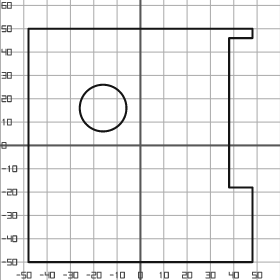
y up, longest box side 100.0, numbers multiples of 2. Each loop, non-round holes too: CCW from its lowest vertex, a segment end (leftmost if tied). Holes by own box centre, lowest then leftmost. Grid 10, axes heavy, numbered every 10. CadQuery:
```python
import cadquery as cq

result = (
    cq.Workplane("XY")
    .moveTo(-48.0, -50.0)
    .lineTo(48.0, -50.0)
    .lineTo(48.0, -18.0)
    .lineTo(38.0, -18.0)
    .lineTo(38.0, 46.0)
    .lineTo(48.0, 46.0)
    .lineTo(48.0, 50.0)
    .lineTo(-48.0, 50.0)
    .close()
    .moveTo(-16.0, 16.0)
    .circle(10.0)
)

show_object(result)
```